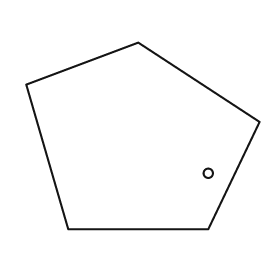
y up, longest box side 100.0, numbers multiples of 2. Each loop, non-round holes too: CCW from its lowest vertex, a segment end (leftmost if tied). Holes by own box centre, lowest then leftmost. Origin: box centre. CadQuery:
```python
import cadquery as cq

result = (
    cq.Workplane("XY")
    .moveTo(-32.0, -40.0)
    .lineTo(28.0, -40.0)
    .lineTo(50.0, 6.0)
    .lineTo(-2.0, 40.0)
    .lineTo(-50.0, 22.0)
    .close()
    .moveTo(28.0, -16.0)
    .circle(2.0)
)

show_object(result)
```